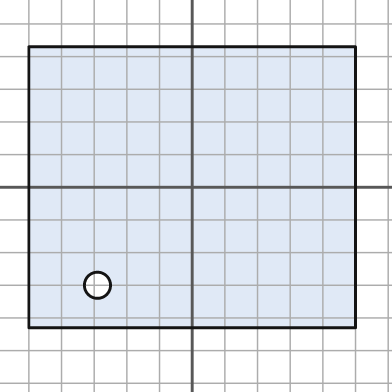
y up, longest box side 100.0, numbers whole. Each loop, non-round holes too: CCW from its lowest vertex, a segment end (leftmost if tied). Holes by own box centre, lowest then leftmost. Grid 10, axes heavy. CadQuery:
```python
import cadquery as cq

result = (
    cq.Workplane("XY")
    .moveTo(-50.0, -43.0)
    .lineTo(50.0, -43.0)
    .lineTo(50.0, 43.0)
    .lineTo(-50.0, 43.0)
    .close()
    .moveTo(-29.0, -30.0)
    .circle(4.0)
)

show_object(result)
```